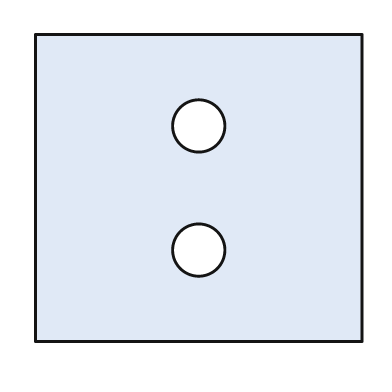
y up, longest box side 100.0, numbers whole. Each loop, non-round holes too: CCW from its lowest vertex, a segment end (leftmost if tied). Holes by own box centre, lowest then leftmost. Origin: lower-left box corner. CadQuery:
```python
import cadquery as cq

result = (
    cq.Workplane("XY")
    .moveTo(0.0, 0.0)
    .lineTo(100.0, 0.0)
    .lineTo(100.0, 94.0)
    .lineTo(0.0, 94.0)
    .close()
    .moveTo(50.0, 28.0)
    .circle(8.0)
    .moveTo(50.0, 66.0)
    .circle(8.0)
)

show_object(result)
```